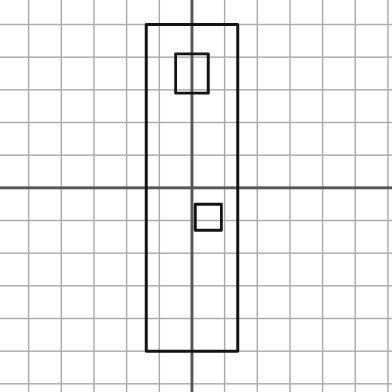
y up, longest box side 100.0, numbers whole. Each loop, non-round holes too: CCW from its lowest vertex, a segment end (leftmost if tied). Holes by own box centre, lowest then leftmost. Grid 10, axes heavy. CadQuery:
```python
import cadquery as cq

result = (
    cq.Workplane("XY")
    .moveTo(-14.0, -50.0)
    .lineTo(14.0, -50.0)
    .lineTo(14.0, 50.0)
    .lineTo(-14.0, 50.0)
    .close()
    .moveTo(1.0, -13.0)
    .lineTo(9.0, -13.0)
    .lineTo(9.0, -5.0)
    .lineTo(1.0, -5.0)
    .close()
    .moveTo(-5.0, 29.0)
    .lineTo(5.0, 29.0)
    .lineTo(5.0, 41.0)
    .lineTo(-5.0, 41.0)
    .close()
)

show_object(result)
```